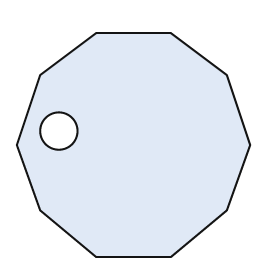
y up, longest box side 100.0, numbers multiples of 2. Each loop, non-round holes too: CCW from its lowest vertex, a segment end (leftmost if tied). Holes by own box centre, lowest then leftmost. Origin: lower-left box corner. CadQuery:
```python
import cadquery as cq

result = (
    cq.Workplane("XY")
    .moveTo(34.0, 0.0)
    .lineTo(66.0, 0.0)
    .lineTo(90.0, 20.0)
    .lineTo(100.0, 48.0)
    .lineTo(90.0, 78.0)
    .lineTo(66.0, 96.0)
    .lineTo(34.0, 96.0)
    .lineTo(10.0, 78.0)
    .lineTo(0.0, 48.0)
    .lineTo(10.0, 20.0)
    .close()
    .moveTo(18.0, 54.0)
    .circle(8.0)
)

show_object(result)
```